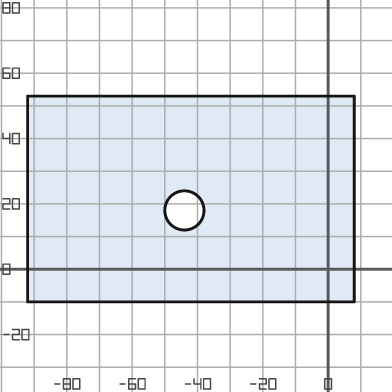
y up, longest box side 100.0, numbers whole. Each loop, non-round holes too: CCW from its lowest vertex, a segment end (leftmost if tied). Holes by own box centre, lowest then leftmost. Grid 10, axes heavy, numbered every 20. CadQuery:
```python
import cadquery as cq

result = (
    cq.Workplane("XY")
    .moveTo(-92.0, -10.0)
    .lineTo(8.0, -10.0)
    .lineTo(8.0, 53.0)
    .lineTo(-92.0, 53.0)
    .close()
    .moveTo(-44.0, 18.0)
    .circle(6.0)
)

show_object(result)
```